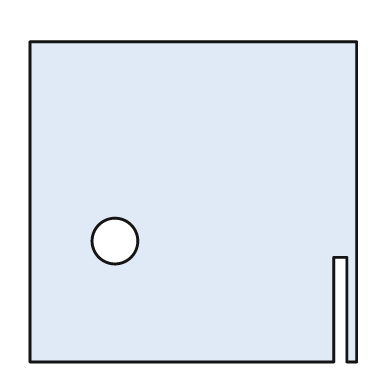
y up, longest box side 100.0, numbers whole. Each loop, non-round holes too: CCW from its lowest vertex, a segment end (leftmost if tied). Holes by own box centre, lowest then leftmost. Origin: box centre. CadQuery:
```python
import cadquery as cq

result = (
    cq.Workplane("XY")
    .moveTo(-50.0, -49.0)
    .lineTo(43.0, -49.0)
    .lineTo(43.0, -17.0)
    .lineTo(47.0, -17.0)
    .lineTo(47.0, -49.0)
    .lineTo(50.0, -49.0)
    .lineTo(50.0, 49.0)
    .lineTo(-50.0, 49.0)
    .close()
    .moveTo(-24.0, -12.0)
    .circle(7.0)
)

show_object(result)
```